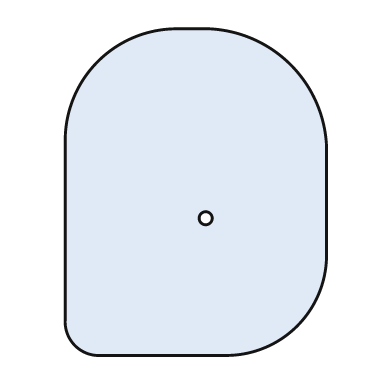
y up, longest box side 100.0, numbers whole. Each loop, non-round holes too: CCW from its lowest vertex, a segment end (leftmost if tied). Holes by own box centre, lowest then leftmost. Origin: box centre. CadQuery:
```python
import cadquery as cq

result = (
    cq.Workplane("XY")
    .moveTo(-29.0, -50.0)
    .lineTo(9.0, -50.0)
    .threePointArc((31.0, -41.0), (40.0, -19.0))
    .lineTo(40.0, 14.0)
    .threePointArc((29.0, 39.0), (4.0, 50.0))
    .lineTo(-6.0, 50.0)
    .threePointArc((-30.0, 40.0), (-40.0, 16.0))
    .lineTo(-40.0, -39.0)
    .threePointArc((-37.0, -47.0), (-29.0, -50.0))
    .close()
    .moveTo(3.0, -8.0)
    .circle(2.0)
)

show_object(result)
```